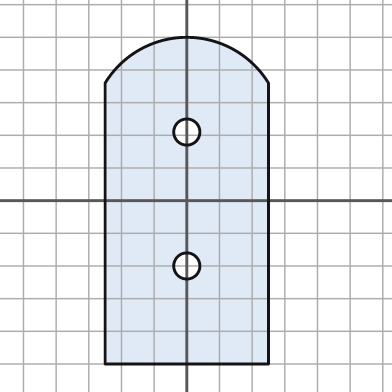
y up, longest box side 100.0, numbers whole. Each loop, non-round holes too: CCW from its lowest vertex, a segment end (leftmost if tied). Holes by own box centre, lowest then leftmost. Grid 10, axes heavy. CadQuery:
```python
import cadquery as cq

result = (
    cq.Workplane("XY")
    .moveTo(-25.0, -50.0)
    .lineTo(25.0, -50.0)
    .lineTo(25.0, 36.0)
    .threePointArc((0.0, 50.0), (-25.0, 36.0))
    .close()
    .moveTo(0.0, -20.0)
    .circle(4.0)
    .moveTo(0.0, 21.0)
    .circle(4.0)
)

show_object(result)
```